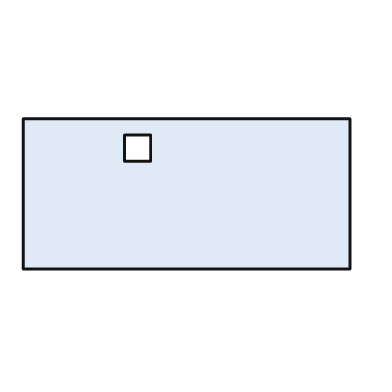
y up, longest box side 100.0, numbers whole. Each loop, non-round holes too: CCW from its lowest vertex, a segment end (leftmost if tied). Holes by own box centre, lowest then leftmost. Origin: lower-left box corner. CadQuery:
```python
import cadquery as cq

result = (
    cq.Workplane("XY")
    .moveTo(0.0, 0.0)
    .lineTo(100.0, 0.0)
    .lineTo(100.0, 46.0)
    .lineTo(0.0, 46.0)
    .close()
    .moveTo(31.0, 33.0)
    .lineTo(39.0, 33.0)
    .lineTo(39.0, 41.0)
    .lineTo(31.0, 41.0)
    .close()
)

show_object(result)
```